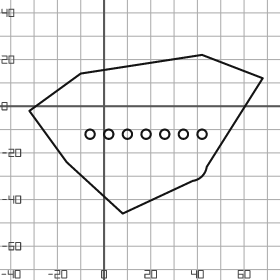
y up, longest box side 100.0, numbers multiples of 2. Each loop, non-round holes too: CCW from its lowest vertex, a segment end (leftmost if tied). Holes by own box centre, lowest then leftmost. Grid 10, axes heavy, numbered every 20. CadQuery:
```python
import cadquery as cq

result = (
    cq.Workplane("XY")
    .moveTo(8.0, -46.0)
    .lineTo(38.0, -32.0)
    .threePointArc((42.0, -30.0), (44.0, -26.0))
    .lineTo(68.0, 12.0)
    .lineTo(42.0, 22.0)
    .lineTo(-10.0, 14.0)
    .lineTo(-32.0, -2.0)
    .lineTo(-16.0, -24.0)
    .close()
    .moveTo(-6.0, -12.0)
    .circle(2.0)
    .moveTo(2.0, -12.0)
    .circle(2.0)
    .moveTo(10.0, -12.0)
    .circle(2.0)
    .moveTo(18.0, -12.0)
    .circle(2.0)
    .moveTo(26.0, -12.0)
    .circle(2.0)
    .moveTo(34.0, -12.0)
    .circle(2.0)
    .moveTo(42.0, -12.0)
    .circle(2.0)
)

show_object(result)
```